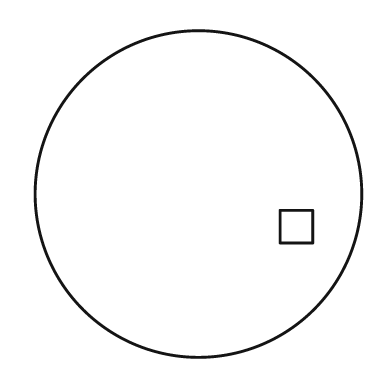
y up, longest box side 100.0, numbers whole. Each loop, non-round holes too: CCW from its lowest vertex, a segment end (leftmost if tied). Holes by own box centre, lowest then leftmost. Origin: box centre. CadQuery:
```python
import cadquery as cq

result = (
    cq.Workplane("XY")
    .moveTo(0.0, 0.0)
    .circle(50.0)
    .moveTo(25.0, -15.0)
    .lineTo(35.0, -15.0)
    .lineTo(35.0, -5.0)
    .lineTo(25.0, -5.0)
    .close()
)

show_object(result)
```